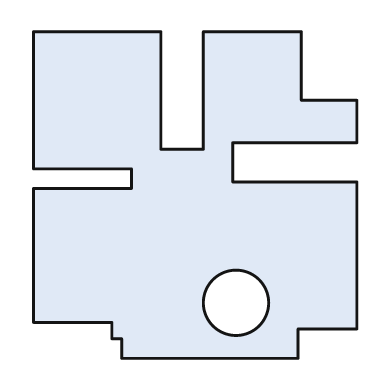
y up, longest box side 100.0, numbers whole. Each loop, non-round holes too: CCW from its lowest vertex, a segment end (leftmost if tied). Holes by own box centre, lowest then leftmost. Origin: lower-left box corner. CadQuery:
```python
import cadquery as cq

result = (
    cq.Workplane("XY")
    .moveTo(27.0, 0.0)
    .lineTo(81.0, 0.0)
    .lineTo(81.0, 9.0)
    .lineTo(99.0, 9.0)
    .lineTo(99.0, 54.0)
    .lineTo(61.0, 54.0)
    .lineTo(61.0, 66.0)
    .lineTo(99.0, 66.0)
    .lineTo(99.0, 79.0)
    .lineTo(82.0, 79.0)
    .lineTo(82.0, 100.0)
    .lineTo(52.0, 100.0)
    .lineTo(52.0, 64.0)
    .lineTo(39.0, 64.0)
    .lineTo(39.0, 100.0)
    .lineTo(0.0, 100.0)
    .lineTo(0.0, 58.0)
    .lineTo(30.0, 58.0)
    .lineTo(30.0, 52.0)
    .lineTo(0.0, 52.0)
    .lineTo(0.0, 11.0)
    .lineTo(24.0, 11.0)
    .lineTo(24.0, 6.0)
    .lineTo(27.0, 6.0)
    .close()
    .moveTo(62.0, 17.0)
    .circle(10.0)
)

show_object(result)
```